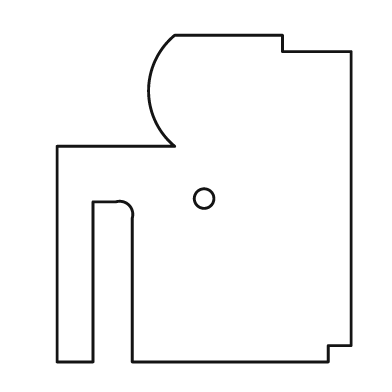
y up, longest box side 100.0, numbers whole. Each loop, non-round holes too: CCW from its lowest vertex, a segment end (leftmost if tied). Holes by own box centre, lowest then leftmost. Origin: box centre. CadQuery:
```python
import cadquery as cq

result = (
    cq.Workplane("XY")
    .moveTo(-45.0, -50.0)
    .lineTo(-34.0, -50.0)
    .lineTo(-34.0, -1.0)
    .lineTo(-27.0, -1.0)
    .threePointArc((-23.0, -2.0), (-22.0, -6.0))
    .lineTo(-22.0, -50.0)
    .lineTo(38.0, -50.0)
    .lineTo(38.0, -45.0)
    .lineTo(45.0, -45.0)
    .lineTo(45.0, 45.0)
    .lineTo(24.0, 45.0)
    .lineTo(24.0, 50.0)
    .lineTo(-9.0, 50.0)
    .threePointArc((-17.0, 33.0), (-9.0, 16.0))
    .lineTo(-45.0, 16.0)
    .close()
    .moveTo(0.0, 0.0)
    .circle(3.0)
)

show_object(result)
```